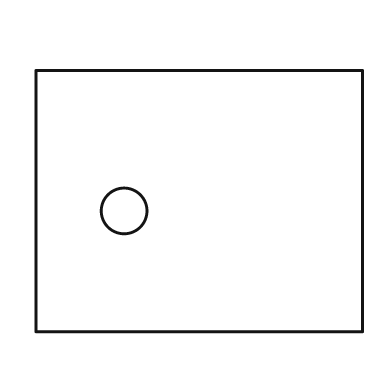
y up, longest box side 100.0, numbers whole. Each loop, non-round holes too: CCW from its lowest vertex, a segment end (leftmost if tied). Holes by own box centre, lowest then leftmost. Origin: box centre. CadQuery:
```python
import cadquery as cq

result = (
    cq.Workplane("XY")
    .moveTo(-50.0, -40.0)
    .lineTo(50.0, -40.0)
    .lineTo(50.0, 40.0)
    .lineTo(-50.0, 40.0)
    .close()
    .moveTo(-23.0, -3.0)
    .circle(7.0)
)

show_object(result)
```